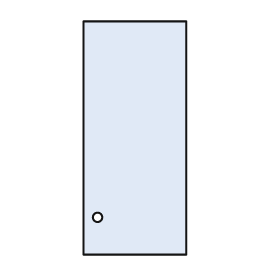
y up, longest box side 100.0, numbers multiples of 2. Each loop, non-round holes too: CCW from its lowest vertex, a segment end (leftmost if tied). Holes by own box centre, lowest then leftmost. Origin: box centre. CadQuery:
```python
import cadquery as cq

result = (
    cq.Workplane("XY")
    .moveTo(-22.0, -50.0)
    .lineTo(22.0, -50.0)
    .lineTo(22.0, 50.0)
    .lineTo(-22.0, 50.0)
    .close()
    .moveTo(-16.0, -34.0)
    .circle(2.0)
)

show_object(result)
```